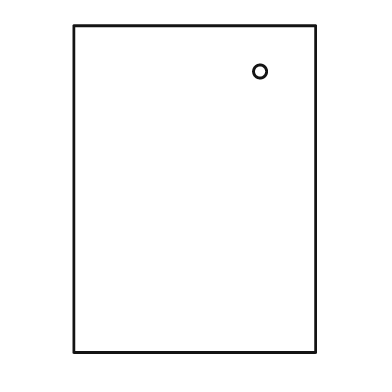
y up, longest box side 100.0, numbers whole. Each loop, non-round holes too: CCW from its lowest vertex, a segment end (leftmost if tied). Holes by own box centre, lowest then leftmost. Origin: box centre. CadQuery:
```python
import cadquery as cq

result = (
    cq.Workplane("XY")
    .moveTo(-37.0, -50.0)
    .lineTo(37.0, -50.0)
    .lineTo(37.0, 50.0)
    .lineTo(-37.0, 50.0)
    .close()
    .moveTo(20.0, 36.0)
    .circle(2.0)
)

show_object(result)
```